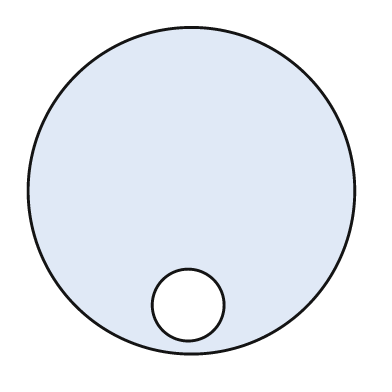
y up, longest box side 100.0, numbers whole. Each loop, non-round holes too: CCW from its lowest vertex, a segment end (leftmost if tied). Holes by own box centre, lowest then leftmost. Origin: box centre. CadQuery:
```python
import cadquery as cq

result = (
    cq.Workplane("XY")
    .moveTo(0.0, 0.0)
    .circle(50.0)
    .moveTo(-1.0, -35.0)
    .circle(11.0)
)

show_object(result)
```